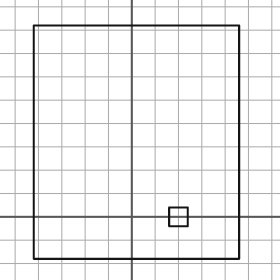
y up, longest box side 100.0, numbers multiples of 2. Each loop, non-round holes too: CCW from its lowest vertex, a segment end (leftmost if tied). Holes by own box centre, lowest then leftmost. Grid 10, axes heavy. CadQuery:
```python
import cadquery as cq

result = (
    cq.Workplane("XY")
    .moveTo(-42.0, -18.0)
    .lineTo(46.0, -18.0)
    .lineTo(46.0, 82.0)
    .lineTo(-42.0, 82.0)
    .close()
    .moveTo(16.0, -4.0)
    .lineTo(24.0, -4.0)
    .lineTo(24.0, 4.0)
    .lineTo(16.0, 4.0)
    .close()
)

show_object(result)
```